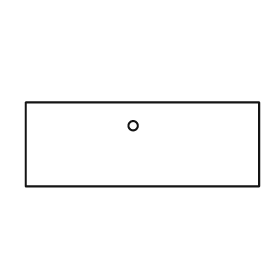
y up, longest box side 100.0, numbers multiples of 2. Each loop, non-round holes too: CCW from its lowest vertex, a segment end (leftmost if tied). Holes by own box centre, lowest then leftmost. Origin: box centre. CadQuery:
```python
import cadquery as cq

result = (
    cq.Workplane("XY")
    .moveTo(-50.0, -18.0)
    .lineTo(50.0, -18.0)
    .lineTo(50.0, 18.0)
    .lineTo(-50.0, 18.0)
    .close()
    .moveTo(-4.0, 8.0)
    .circle(2.0)
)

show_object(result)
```